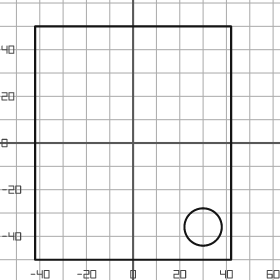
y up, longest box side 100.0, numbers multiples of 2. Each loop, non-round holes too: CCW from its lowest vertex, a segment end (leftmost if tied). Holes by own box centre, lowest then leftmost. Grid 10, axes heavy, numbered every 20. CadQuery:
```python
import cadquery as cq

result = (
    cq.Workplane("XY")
    .moveTo(-42.0, -50.0)
    .lineTo(42.0, -50.0)
    .lineTo(42.0, 50.0)
    .lineTo(-42.0, 50.0)
    .close()
    .moveTo(30.0, -36.0)
    .circle(8.0)
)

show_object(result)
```